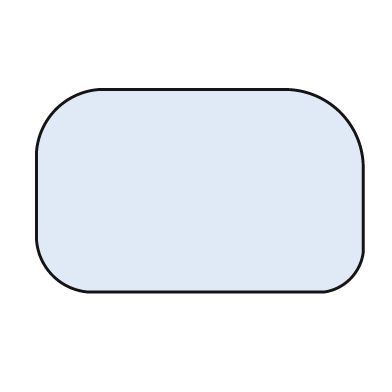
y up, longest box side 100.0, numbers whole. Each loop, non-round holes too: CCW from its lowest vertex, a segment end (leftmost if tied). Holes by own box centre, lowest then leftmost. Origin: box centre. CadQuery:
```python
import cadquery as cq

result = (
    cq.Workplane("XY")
    .moveTo(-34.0, -31.0)
    .lineTo(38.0, -31.0)
    .threePointArc((46.0, -27.0), (50.0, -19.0))
    .lineTo(50.0, 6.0)
    .threePointArc((43.0, 24.0), (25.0, 31.0))
    .lineTo(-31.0, 31.0)
    .threePointArc((-44.0, 25.0), (-50.0, 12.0))
    .lineTo(-50.0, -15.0)
    .threePointArc((-45.0, -26.0), (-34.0, -31.0))
    .close()
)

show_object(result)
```